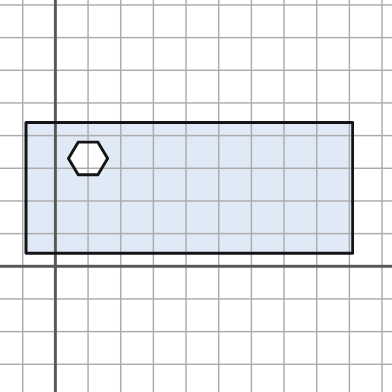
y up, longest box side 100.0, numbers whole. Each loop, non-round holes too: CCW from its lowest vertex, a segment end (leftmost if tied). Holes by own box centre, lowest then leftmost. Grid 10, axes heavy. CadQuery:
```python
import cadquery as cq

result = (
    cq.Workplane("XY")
    .moveTo(-9.0, 4.0)
    .lineTo(91.0, 4.0)
    .lineTo(91.0, 44.0)
    .lineTo(-9.0, 44.0)
    .close()
    .moveTo(7.0, 28.0)
    .lineTo(13.0, 28.0)
    .lineTo(16.0, 33.0)
    .lineTo(13.0, 38.0)
    .lineTo(7.0, 38.0)
    .lineTo(4.0, 33.0)
    .close()
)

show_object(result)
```